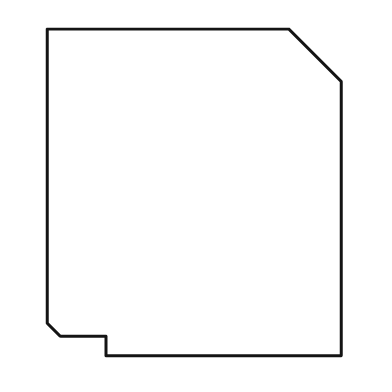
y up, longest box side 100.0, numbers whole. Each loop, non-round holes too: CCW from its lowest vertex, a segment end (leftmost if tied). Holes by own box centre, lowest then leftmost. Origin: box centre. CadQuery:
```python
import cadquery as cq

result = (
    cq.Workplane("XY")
    .moveTo(-27.0, -50.0)
    .lineTo(45.0, -50.0)
    .lineTo(45.0, 34.0)
    .lineTo(29.0, 50.0)
    .lineTo(-45.0, 50.0)
    .lineTo(-45.0, -40.0)
    .lineTo(-41.0, -44.0)
    .lineTo(-27.0, -44.0)
    .close()
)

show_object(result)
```